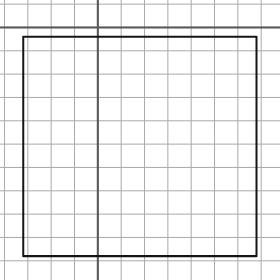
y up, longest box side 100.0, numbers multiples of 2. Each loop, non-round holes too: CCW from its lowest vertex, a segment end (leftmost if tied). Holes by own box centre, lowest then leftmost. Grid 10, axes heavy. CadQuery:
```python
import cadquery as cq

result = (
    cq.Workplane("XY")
    .moveTo(-32.0, -98.0)
    .lineTo(68.0, -98.0)
    .lineTo(68.0, -4.0)
    .lineTo(-32.0, -4.0)
    .close()
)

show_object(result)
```